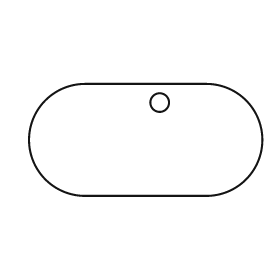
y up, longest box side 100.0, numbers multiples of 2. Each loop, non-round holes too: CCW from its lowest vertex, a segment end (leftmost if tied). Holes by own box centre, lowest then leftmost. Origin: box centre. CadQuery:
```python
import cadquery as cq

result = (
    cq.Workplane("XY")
    .moveTo(-26.0, -24.0)
    .lineTo(26.0, -24.0)
    .threePointArc((50.0, 0.0), (26.0, 24.0))
    .lineTo(-26.0, 24.0)
    .threePointArc((-50.0, 0.0), (-26.0, -24.0))
    .close()
    .moveTo(6.0, 16.0)
    .circle(4.0)
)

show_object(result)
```